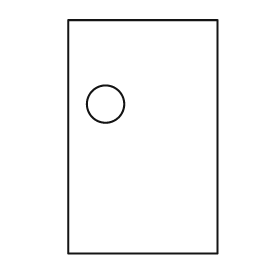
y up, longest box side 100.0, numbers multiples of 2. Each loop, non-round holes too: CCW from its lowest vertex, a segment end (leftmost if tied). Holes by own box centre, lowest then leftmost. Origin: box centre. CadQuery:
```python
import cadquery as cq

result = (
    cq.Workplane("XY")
    .moveTo(-32.0, -50.0)
    .lineTo(32.0, -50.0)
    .lineTo(32.0, 50.0)
    .lineTo(-32.0, 50.0)
    .close()
    .moveTo(-16.0, 14.0)
    .circle(8.0)
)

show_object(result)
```